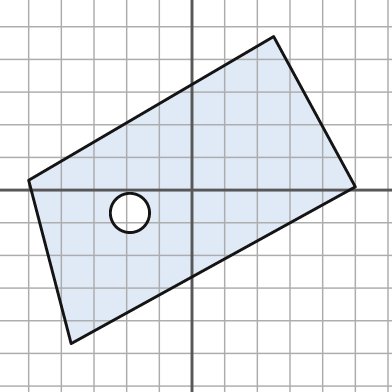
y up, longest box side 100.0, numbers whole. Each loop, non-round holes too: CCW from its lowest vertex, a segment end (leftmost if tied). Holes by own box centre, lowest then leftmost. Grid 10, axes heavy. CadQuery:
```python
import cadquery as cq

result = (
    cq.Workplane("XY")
    .moveTo(-37.0, -47.0)
    .lineTo(50.0, 1.0)
    .lineTo(25.0, 47.0)
    .lineTo(-50.0, 3.0)
    .close()
    .moveTo(-19.0, -7.0)
    .circle(6.0)
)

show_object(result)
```